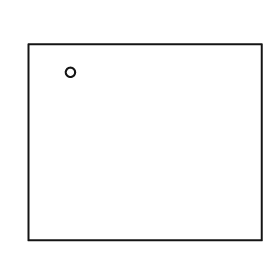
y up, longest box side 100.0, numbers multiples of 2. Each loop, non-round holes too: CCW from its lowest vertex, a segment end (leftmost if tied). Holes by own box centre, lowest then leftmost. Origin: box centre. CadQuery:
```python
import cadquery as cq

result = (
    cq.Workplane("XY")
    .moveTo(-50.0, -42.0)
    .lineTo(50.0, -42.0)
    .lineTo(50.0, 42.0)
    .lineTo(-50.0, 42.0)
    .close()
    .moveTo(-32.0, 30.0)
    .circle(2.0)
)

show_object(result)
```